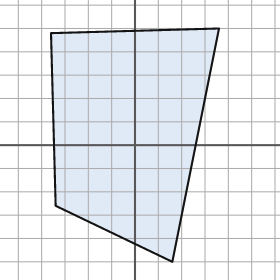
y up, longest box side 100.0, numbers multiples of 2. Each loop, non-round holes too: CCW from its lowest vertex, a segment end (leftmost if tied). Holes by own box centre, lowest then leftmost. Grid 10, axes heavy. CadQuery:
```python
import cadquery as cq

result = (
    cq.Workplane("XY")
    .moveTo(16.0, -50.0)
    .lineTo(36.0, 50.0)
    .lineTo(-36.0, 48.0)
    .lineTo(-34.0, -26.0)
    .close()
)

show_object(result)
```